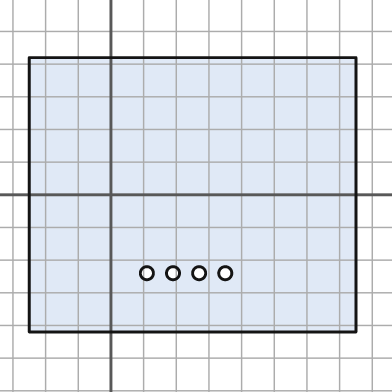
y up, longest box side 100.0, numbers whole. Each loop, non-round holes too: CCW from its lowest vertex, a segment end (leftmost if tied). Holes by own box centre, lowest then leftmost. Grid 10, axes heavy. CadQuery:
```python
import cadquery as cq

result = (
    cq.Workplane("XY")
    .moveTo(-25.0, -42.0)
    .lineTo(75.0, -42.0)
    .lineTo(75.0, 42.0)
    .lineTo(-25.0, 42.0)
    .close()
    .moveTo(11.0, -24.0)
    .circle(2.0)
    .moveTo(19.0, -24.0)
    .circle(2.0)
    .moveTo(27.0, -24.0)
    .circle(2.0)
    .moveTo(35.0, -24.0)
    .circle(2.0)
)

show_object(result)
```